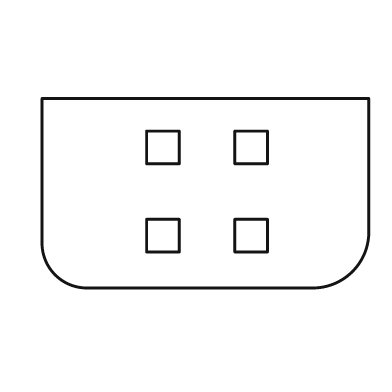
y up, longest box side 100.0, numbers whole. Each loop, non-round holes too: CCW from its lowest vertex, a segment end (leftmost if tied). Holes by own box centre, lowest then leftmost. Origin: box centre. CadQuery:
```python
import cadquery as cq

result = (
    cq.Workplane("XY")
    .moveTo(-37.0, -29.0)
    .lineTo(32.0, -29.0)
    .threePointArc((45.0, -24.0), (50.0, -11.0))
    .lineTo(50.0, 29.0)
    .lineTo(-50.0, 29.0)
    .lineTo(-50.0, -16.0)
    .threePointArc((-46.0, -25.0), (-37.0, -29.0))
    .close()
    .moveTo(-18.0, -18.0)
    .lineTo(-8.0, -18.0)
    .lineTo(-8.0, -8.0)
    .lineTo(-18.0, -8.0)
    .close()
    .moveTo(9.0, -18.0)
    .lineTo(19.0, -18.0)
    .lineTo(19.0, -8.0)
    .lineTo(9.0, -8.0)
    .close()
    .moveTo(-18.0, 9.0)
    .lineTo(-8.0, 9.0)
    .lineTo(-8.0, 19.0)
    .lineTo(-18.0, 19.0)
    .close()
    .moveTo(9.0, 9.0)
    .lineTo(19.0, 9.0)
    .lineTo(19.0, 19.0)
    .lineTo(9.0, 19.0)
    .close()
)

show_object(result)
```